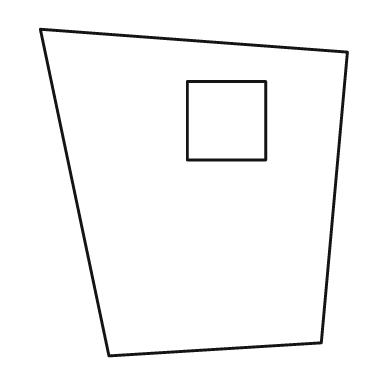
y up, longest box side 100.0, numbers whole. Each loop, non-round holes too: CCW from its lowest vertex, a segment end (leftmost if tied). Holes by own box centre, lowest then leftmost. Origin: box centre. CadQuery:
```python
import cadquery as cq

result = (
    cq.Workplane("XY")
    .moveTo(-26.0, -50.0)
    .lineTo(39.0, -46.0)
    .lineTo(47.0, 43.0)
    .lineTo(-47.0, 50.0)
    .close()
    .moveTo(-2.0, 10.0)
    .lineTo(22.0, 10.0)
    .lineTo(22.0, 34.0)
    .lineTo(-2.0, 34.0)
    .close()
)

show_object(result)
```